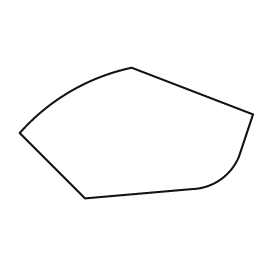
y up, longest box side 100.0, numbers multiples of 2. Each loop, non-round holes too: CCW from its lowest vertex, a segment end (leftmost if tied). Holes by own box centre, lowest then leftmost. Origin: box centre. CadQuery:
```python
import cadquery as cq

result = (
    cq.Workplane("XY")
    .moveTo(-22.0, -28.0)
    .lineTo(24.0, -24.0)
    .threePointArc((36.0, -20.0), (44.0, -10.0))
    .lineTo(50.0, 8.0)
    .lineTo(-2.0, 28.0)
    .threePointArc((-28.0, 18.0), (-50.0, 0.0))
    .close()
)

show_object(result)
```